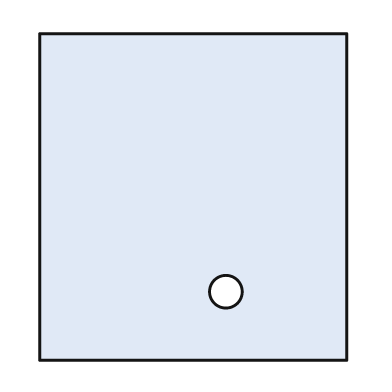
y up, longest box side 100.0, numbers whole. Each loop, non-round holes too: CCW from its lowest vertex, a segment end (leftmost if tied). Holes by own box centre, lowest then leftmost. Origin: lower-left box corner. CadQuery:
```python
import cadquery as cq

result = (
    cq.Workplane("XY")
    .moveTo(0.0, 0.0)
    .lineTo(94.0, 0.0)
    .lineTo(94.0, 100.0)
    .lineTo(0.0, 100.0)
    .close()
    .moveTo(57.0, 21.0)
    .circle(5.0)
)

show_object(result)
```